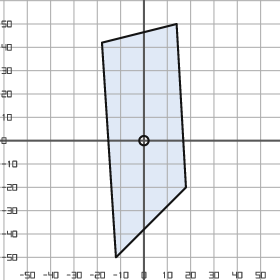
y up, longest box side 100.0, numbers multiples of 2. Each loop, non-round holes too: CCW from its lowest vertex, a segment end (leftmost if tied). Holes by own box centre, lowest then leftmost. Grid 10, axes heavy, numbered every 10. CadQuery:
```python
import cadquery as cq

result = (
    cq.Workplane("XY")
    .moveTo(-12.0, -50.0)
    .lineTo(18.0, -20.0)
    .lineTo(14.0, 50.0)
    .lineTo(-18.0, 42.0)
    .close()
    .moveTo(0.0, 0.0)
    .circle(2.0)
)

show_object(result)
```